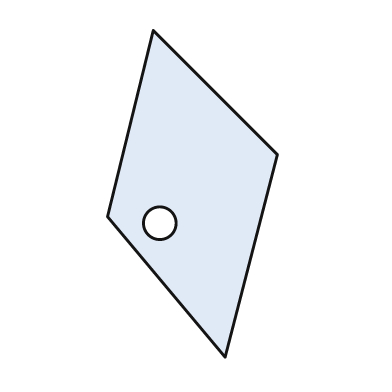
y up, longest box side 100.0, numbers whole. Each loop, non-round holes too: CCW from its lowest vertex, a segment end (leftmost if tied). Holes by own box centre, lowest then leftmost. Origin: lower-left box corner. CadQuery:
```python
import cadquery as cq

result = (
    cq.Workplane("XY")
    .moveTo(36.0, 0.0)
    .lineTo(52.0, 62.0)
    .lineTo(14.0, 100.0)
    .lineTo(0.0, 43.0)
    .close()
    .moveTo(16.0, 41.0)
    .circle(5.0)
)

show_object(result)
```